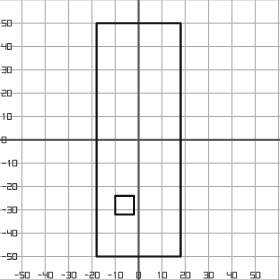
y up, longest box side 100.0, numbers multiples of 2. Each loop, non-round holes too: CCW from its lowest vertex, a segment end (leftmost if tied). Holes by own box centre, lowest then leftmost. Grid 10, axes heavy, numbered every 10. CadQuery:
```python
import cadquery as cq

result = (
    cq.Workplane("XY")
    .moveTo(-18.0, -50.0)
    .lineTo(18.0, -50.0)
    .lineTo(18.0, 50.0)
    .lineTo(-18.0, 50.0)
    .close()
    .moveTo(-10.0, -32.0)
    .lineTo(-2.0, -32.0)
    .lineTo(-2.0, -24.0)
    .lineTo(-10.0, -24.0)
    .close()
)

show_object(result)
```